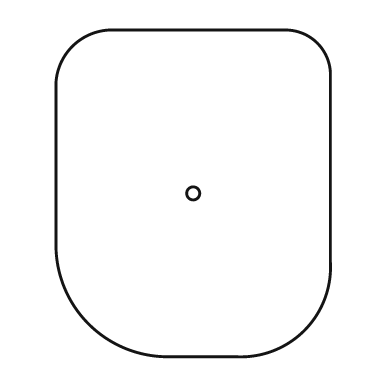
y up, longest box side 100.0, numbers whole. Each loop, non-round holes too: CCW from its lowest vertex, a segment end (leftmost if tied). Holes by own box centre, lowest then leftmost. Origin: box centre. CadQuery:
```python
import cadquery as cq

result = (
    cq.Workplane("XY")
    .moveTo(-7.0, -50.0)
    .lineTo(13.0, -50.0)
    .threePointArc((34.0, -42.0), (42.0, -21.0))
    .lineTo(42.0, 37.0)
    .threePointArc((38.0, 46.0), (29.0, 50.0))
    .lineTo(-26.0, 50.0)
    .threePointArc((-37.0, 45.0), (-42.0, 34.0))
    .lineTo(-42.0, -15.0)
    .threePointArc((-32.0, -40.0), (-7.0, -50.0))
    .close()
    .moveTo(0.0, 0.0)
    .circle(2.0)
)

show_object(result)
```